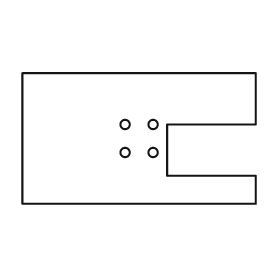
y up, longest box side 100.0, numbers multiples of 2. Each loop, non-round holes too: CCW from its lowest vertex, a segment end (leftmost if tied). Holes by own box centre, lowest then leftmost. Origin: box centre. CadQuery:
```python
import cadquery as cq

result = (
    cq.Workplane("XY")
    .moveTo(-50.0, -28.0)
    .lineTo(50.0, -28.0)
    .lineTo(50.0, -16.0)
    .lineTo(12.0, -16.0)
    .lineTo(12.0, 6.0)
    .lineTo(50.0, 6.0)
    .lineTo(50.0, 28.0)
    .lineTo(-50.0, 28.0)
    .close()
    .moveTo(-6.0, -6.0)
    .circle(2.0)
    .moveTo(6.0, -6.0)
    .circle(2.0)
    .moveTo(-6.0, 6.0)
    .circle(2.0)
    .moveTo(6.0, 6.0)
    .circle(2.0)
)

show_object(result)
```